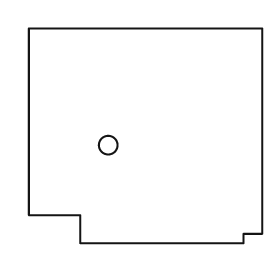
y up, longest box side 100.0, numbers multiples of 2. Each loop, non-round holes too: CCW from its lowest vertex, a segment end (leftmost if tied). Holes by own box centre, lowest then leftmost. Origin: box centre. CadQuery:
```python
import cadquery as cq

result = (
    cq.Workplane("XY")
    .moveTo(-28.0, -46.0)
    .lineTo(42.0, -46.0)
    .lineTo(42.0, -42.0)
    .lineTo(50.0, -42.0)
    .lineTo(50.0, 46.0)
    .lineTo(-50.0, 46.0)
    .lineTo(-50.0, -34.0)
    .lineTo(-28.0, -34.0)
    .close()
    .moveTo(-16.0, -4.0)
    .circle(4.0)
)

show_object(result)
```